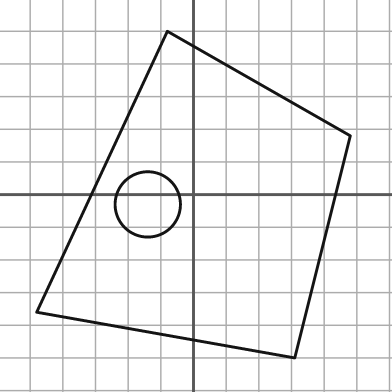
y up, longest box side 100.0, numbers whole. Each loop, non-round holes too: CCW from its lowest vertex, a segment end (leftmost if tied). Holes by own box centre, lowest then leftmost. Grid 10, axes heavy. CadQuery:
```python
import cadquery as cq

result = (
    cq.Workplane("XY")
    .moveTo(31.0, -50.0)
    .lineTo(48.0, 18.0)
    .lineTo(-8.0, 50.0)
    .lineTo(-48.0, -36.0)
    .close()
    .moveTo(-14.0, -3.0)
    .circle(10.0)
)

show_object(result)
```